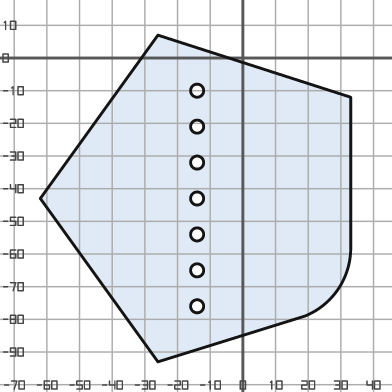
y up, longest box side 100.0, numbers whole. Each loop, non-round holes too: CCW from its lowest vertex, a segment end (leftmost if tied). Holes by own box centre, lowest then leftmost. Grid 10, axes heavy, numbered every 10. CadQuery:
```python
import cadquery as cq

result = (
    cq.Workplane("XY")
    .moveTo(-26.0, -93.0)
    .lineTo(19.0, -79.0)
    .threePointArc((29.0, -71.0), (33.0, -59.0))
    .lineTo(33.0, -12.0)
    .lineTo(-26.0, 7.0)
    .lineTo(-62.0, -43.0)
    .close()
    .moveTo(-14.0, -76.0)
    .circle(2.0)
    .moveTo(-14.0, -65.0)
    .circle(2.0)
    .moveTo(-14.0, -54.0)
    .circle(2.0)
    .moveTo(-14.0, -43.0)
    .circle(2.0)
    .moveTo(-14.0, -32.0)
    .circle(2.0)
    .moveTo(-14.0, -21.0)
    .circle(2.0)
    .moveTo(-14.0, -10.0)
    .circle(2.0)
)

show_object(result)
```